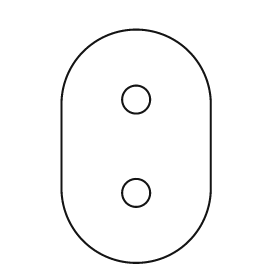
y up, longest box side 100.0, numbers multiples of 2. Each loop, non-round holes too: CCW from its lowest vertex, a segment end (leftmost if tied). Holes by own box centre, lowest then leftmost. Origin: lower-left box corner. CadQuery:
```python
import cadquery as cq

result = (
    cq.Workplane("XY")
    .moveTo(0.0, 32.0)
    .threePointArc((32.0, 0.0), (64.0, 32.0))
    .lineTo(64.0, 68.0)
    .threePointArc((32.0, 100.0), (0.0, 68.0))
    .close()
    .moveTo(32.0, 30.0)
    .circle(6.0)
    .moveTo(32.0, 70.0)
    .circle(6.0)
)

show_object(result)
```